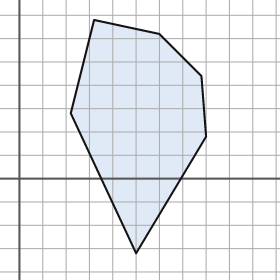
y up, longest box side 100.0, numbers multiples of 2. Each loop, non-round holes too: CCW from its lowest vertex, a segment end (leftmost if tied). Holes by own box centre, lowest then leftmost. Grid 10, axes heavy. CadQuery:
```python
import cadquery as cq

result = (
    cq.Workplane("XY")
    .moveTo(50.0, -32.0)
    .lineTo(80.0, 18.0)
    .lineTo(78.0, 44.0)
    .lineTo(60.0, 62.0)
    .lineTo(32.0, 68.0)
    .lineTo(22.0, 28.0)
    .close()
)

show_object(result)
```